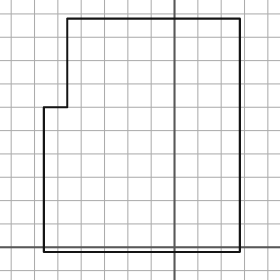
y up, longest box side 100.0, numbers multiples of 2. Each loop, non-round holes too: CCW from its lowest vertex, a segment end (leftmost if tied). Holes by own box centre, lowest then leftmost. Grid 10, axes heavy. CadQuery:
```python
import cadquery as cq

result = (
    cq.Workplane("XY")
    .moveTo(-56.0, -2.0)
    .lineTo(28.0, -2.0)
    .lineTo(28.0, 98.0)
    .lineTo(-46.0, 98.0)
    .lineTo(-46.0, 60.0)
    .lineTo(-56.0, 60.0)
    .close()
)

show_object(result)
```